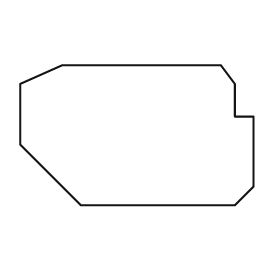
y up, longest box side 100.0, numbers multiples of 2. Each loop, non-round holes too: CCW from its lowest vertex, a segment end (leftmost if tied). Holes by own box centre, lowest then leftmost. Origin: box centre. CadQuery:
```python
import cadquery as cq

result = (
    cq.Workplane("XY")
    .moveTo(-24.0, -30.0)
    .lineTo(42.0, -30.0)
    .lineTo(50.0, -22.0)
    .lineTo(50.0, 8.0)
    .lineTo(42.0, 8.0)
    .lineTo(42.0, 22.0)
    .lineTo(36.0, 30.0)
    .lineTo(-32.0, 30.0)
    .lineTo(-50.0, 22.0)
    .lineTo(-50.0, -4.0)
    .close()
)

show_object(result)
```